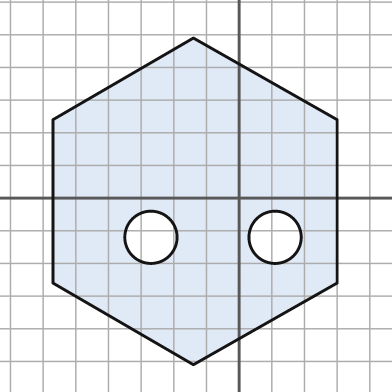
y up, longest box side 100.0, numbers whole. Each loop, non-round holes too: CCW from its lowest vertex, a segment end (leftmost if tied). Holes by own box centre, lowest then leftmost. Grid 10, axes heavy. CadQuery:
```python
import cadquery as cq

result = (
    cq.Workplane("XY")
    .moveTo(-14.0, -51.0)
    .lineTo(30.0, -26.0)
    .lineTo(30.0, 24.0)
    .lineTo(-14.0, 49.0)
    .lineTo(-57.0, 24.0)
    .lineTo(-57.0, -26.0)
    .close()
    .moveTo(-27.0, -12.0)
    .circle(8.0)
    .moveTo(11.0, -12.0)
    .circle(8.0)
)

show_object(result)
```